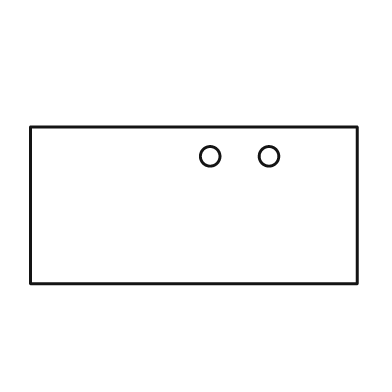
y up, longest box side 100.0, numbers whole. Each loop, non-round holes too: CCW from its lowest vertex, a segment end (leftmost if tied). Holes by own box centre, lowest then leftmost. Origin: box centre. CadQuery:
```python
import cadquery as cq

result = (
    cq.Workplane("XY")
    .moveTo(-50.0, -24.0)
    .lineTo(50.0, -24.0)
    .lineTo(50.0, 24.0)
    .lineTo(-50.0, 24.0)
    .close()
    .moveTo(5.0, 15.0)
    .circle(3.0)
    .moveTo(23.0, 15.0)
    .circle(3.0)
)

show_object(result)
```